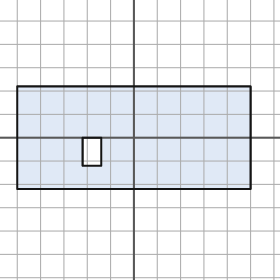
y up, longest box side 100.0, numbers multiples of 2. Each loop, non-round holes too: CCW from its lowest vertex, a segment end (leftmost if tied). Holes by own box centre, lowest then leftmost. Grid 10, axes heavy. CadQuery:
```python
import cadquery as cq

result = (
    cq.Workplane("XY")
    .moveTo(-50.0, -22.0)
    .lineTo(50.0, -22.0)
    .lineTo(50.0, 22.0)
    .lineTo(-50.0, 22.0)
    .close()
    .moveTo(-22.0, -12.0)
    .lineTo(-14.0, -12.0)
    .lineTo(-14.0, 0.0)
    .lineTo(-22.0, 0.0)
    .close()
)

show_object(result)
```